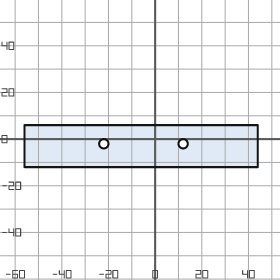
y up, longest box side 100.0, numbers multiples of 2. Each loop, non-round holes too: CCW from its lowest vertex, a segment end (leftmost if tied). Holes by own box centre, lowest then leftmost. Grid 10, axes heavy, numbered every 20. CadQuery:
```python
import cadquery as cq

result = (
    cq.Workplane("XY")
    .moveTo(-56.0, -12.0)
    .lineTo(44.0, -12.0)
    .lineTo(44.0, 6.0)
    .lineTo(-56.0, 6.0)
    .close()
    .moveTo(-22.0, -2.0)
    .circle(2.0)
    .moveTo(12.0, -2.0)
    .circle(2.0)
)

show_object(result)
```